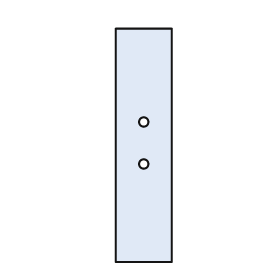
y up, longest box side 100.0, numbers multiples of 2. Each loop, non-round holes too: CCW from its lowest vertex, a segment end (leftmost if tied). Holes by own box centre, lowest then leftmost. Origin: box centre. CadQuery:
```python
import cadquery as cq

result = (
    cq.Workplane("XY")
    .moveTo(-12.0, -50.0)
    .lineTo(12.0, -50.0)
    .lineTo(12.0, 50.0)
    .lineTo(-12.0, 50.0)
    .close()
    .moveTo(0.0, -8.0)
    .circle(2.0)
    .moveTo(0.0, 10.0)
    .circle(2.0)
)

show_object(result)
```